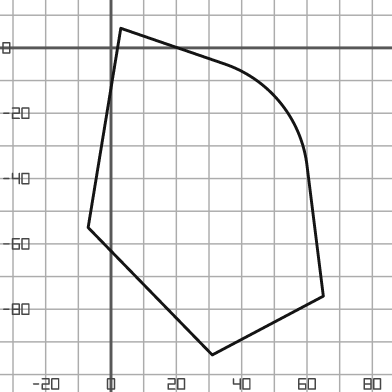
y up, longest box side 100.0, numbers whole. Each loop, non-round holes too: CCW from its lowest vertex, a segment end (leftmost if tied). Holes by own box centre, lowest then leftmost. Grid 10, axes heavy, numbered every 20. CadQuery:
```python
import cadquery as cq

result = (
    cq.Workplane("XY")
    .moveTo(31.0, -94.0)
    .lineTo(65.0, -76.0)
    .lineTo(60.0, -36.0)
    .threePointArc((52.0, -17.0), (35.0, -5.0))
    .lineTo(3.0, 6.0)
    .lineTo(-7.0, -55.0)
    .close()
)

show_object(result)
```